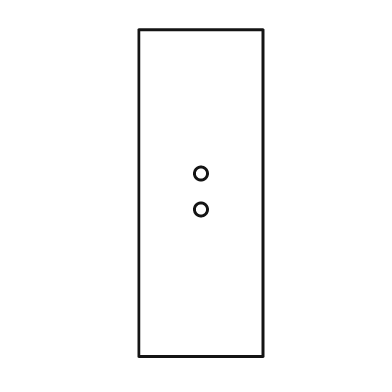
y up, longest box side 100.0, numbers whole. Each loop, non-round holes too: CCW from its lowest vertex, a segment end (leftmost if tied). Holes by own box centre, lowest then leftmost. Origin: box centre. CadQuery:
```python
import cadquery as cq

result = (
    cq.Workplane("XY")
    .moveTo(-19.0, -50.0)
    .lineTo(19.0, -50.0)
    .lineTo(19.0, 50.0)
    .lineTo(-19.0, 50.0)
    .close()
    .moveTo(0.0, -5.0)
    .circle(2.0)
    .moveTo(0.0, 6.0)
    .circle(2.0)
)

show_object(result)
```